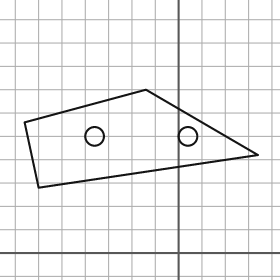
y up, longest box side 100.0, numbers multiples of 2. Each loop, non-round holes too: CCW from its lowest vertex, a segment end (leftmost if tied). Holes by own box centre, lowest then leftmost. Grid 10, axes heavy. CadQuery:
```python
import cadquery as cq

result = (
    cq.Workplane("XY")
    .moveTo(-60.0, 28.0)
    .lineTo(34.0, 42.0)
    .lineTo(-14.0, 70.0)
    .lineTo(-66.0, 56.0)
    .close()
    .moveTo(-36.0, 50.0)
    .circle(4.0)
    .moveTo(4.0, 50.0)
    .circle(4.0)
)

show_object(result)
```